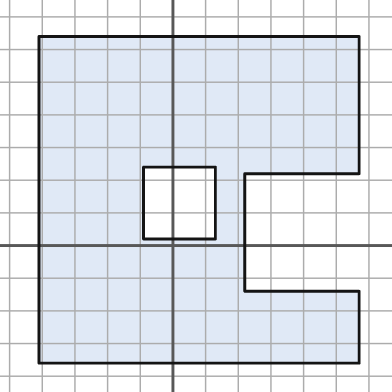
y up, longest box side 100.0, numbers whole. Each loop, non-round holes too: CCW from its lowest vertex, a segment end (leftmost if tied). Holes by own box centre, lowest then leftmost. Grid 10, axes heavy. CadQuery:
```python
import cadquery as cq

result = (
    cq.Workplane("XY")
    .moveTo(-41.0, -36.0)
    .lineTo(57.0, -36.0)
    .lineTo(57.0, -14.0)
    .lineTo(22.0, -14.0)
    .lineTo(22.0, 22.0)
    .lineTo(57.0, 22.0)
    .lineTo(57.0, 64.0)
    .lineTo(-41.0, 64.0)
    .close()
    .moveTo(-9.0, 2.0)
    .lineTo(13.0, 2.0)
    .lineTo(13.0, 24.0)
    .lineTo(-9.0, 24.0)
    .close()
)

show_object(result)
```